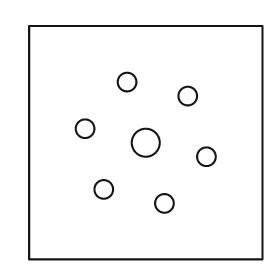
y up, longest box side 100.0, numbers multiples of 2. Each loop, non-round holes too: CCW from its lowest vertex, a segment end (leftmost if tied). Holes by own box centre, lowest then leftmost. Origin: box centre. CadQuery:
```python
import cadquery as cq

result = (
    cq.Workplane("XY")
    .moveTo(-50.0, -50.0)
    .lineTo(50.0, -50.0)
    .lineTo(50.0, 50.0)
    .lineTo(-50.0, 50.0)
    .close()
    .moveTo(8.0, -26.0)
    .circle(4.0)
    .moveTo(-18.0, -20.0)
    .circle(4.0)
    .moveTo(26.0, -6.0)
    .circle(4.0)
    .moveTo(0.0, 0.0)
    .circle(6.0)
    .moveTo(-26.0, 6.0)
    .circle(4.0)
    .moveTo(18.0, 20.0)
    .circle(4.0)
    .moveTo(-8.0, 26.0)
    .circle(4.0)
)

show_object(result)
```